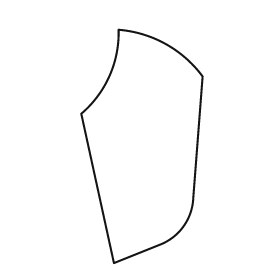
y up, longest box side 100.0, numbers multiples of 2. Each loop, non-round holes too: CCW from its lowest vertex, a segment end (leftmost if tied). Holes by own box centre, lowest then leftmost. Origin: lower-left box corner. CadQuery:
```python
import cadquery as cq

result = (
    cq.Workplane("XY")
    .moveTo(14.0, 0.0)
    .lineTo(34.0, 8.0)
    .threePointArc((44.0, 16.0), (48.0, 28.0))
    .lineTo(52.0, 80.0)
    .threePointArc((36.0, 94.0), (16.0, 100.0))
    .threePointArc((12.0, 80.0), (0.0, 64.0))
    .close()
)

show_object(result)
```